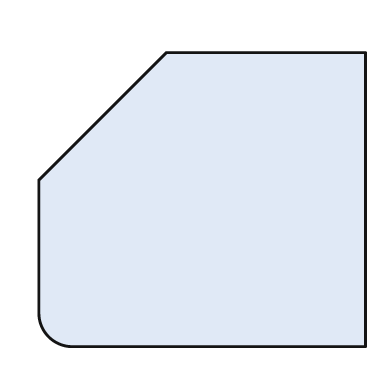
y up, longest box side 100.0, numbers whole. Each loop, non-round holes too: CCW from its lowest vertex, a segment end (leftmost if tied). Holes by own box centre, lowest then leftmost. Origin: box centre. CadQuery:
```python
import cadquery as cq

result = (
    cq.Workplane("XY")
    .moveTo(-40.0, -45.0)
    .lineTo(50.0, -45.0)
    .lineTo(50.0, 45.0)
    .lineTo(-11.0, 45.0)
    .lineTo(-50.0, 6.0)
    .lineTo(-50.0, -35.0)
    .threePointArc((-47.0, -42.0), (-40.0, -45.0))
    .close()
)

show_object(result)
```